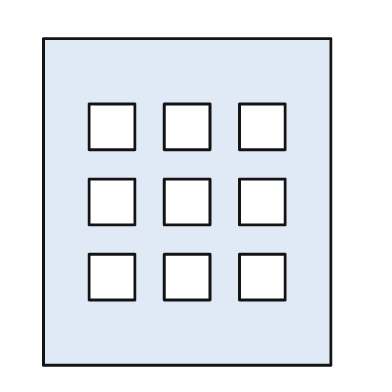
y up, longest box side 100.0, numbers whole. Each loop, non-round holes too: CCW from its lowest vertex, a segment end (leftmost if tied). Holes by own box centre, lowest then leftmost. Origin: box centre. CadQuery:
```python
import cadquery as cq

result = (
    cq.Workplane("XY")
    .moveTo(-44.0, -50.0)
    .lineTo(44.0, -50.0)
    .lineTo(44.0, 50.0)
    .lineTo(-44.0, 50.0)
    .close()
    .moveTo(-30.0, -30.0)
    .lineTo(-16.0, -30.0)
    .lineTo(-16.0, -16.0)
    .lineTo(-30.0, -16.0)
    .close()
    .moveTo(-7.0, -30.0)
    .lineTo(7.0, -30.0)
    .lineTo(7.0, -16.0)
    .lineTo(-7.0, -16.0)
    .close()
    .moveTo(16.0, -30.0)
    .lineTo(30.0, -30.0)
    .lineTo(30.0, -16.0)
    .lineTo(16.0, -16.0)
    .close()
    .moveTo(-30.0, -7.0)
    .lineTo(-16.0, -7.0)
    .lineTo(-16.0, 7.0)
    .lineTo(-30.0, 7.0)
    .close()
    .moveTo(-7.0, -7.0)
    .lineTo(7.0, -7.0)
    .lineTo(7.0, 7.0)
    .lineTo(-7.0, 7.0)
    .close()
    .moveTo(16.0, -7.0)
    .lineTo(30.0, -7.0)
    .lineTo(30.0, 7.0)
    .lineTo(16.0, 7.0)
    .close()
    .moveTo(-30.0, 16.0)
    .lineTo(-16.0, 16.0)
    .lineTo(-16.0, 30.0)
    .lineTo(-30.0, 30.0)
    .close()
    .moveTo(-7.0, 16.0)
    .lineTo(7.0, 16.0)
    .lineTo(7.0, 30.0)
    .lineTo(-7.0, 30.0)
    .close()
    .moveTo(16.0, 16.0)
    .lineTo(30.0, 16.0)
    .lineTo(30.0, 30.0)
    .lineTo(16.0, 30.0)
    .close()
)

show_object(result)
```